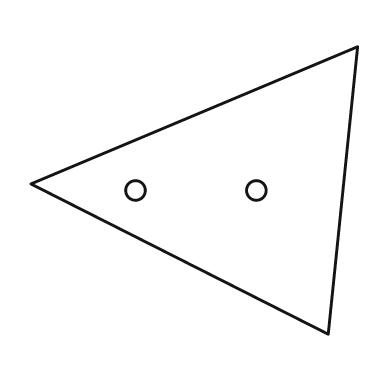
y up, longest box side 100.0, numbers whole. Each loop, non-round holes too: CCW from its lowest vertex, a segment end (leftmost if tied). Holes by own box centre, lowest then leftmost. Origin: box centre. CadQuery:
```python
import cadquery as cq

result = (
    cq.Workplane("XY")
    .moveTo(41.0, -44.0)
    .lineTo(50.0, 44.0)
    .lineTo(-50.0, 2.0)
    .close()
    .moveTo(-18.0, 0.0)
    .circle(3.0)
    .moveTo(19.0, 0.0)
    .circle(3.0)
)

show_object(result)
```